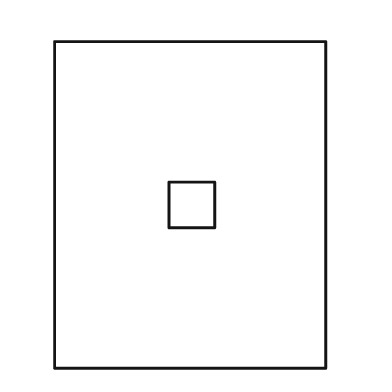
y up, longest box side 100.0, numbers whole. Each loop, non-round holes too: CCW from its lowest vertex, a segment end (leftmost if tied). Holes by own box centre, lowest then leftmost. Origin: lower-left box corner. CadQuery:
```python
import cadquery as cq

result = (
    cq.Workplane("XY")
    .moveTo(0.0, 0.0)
    .lineTo(83.0, 0.0)
    .lineTo(83.0, 100.0)
    .lineTo(0.0, 100.0)
    .close()
    .moveTo(35.0, 43.0)
    .lineTo(49.0, 43.0)
    .lineTo(49.0, 57.0)
    .lineTo(35.0, 57.0)
    .close()
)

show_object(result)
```